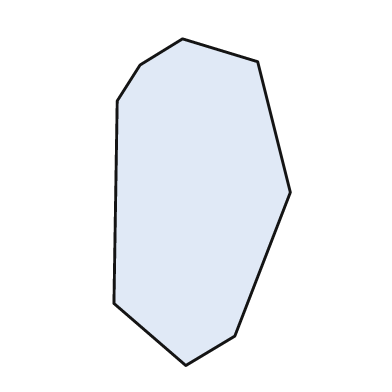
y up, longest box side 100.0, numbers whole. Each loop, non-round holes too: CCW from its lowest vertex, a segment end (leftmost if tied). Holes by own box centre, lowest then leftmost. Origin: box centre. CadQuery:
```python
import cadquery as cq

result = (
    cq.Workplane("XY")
    .moveTo(-5.0, -50.0)
    .lineTo(10.0, -41.0)
    .lineTo(27.0, 3.0)
    .lineTo(17.0, 43.0)
    .lineTo(-6.0, 50.0)
    .lineTo(-19.0, 42.0)
    .lineTo(-26.0, 31.0)
    .lineTo(-27.0, -31.0)
    .close()
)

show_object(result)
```